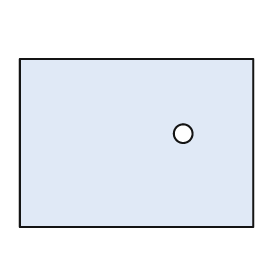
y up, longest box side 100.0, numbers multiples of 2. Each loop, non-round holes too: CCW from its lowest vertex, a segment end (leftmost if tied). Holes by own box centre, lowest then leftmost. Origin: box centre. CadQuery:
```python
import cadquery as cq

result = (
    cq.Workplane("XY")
    .moveTo(-50.0, -36.0)
    .lineTo(50.0, -36.0)
    .lineTo(50.0, 36.0)
    .lineTo(-50.0, 36.0)
    .close()
    .moveTo(20.0, 4.0)
    .circle(4.0)
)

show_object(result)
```